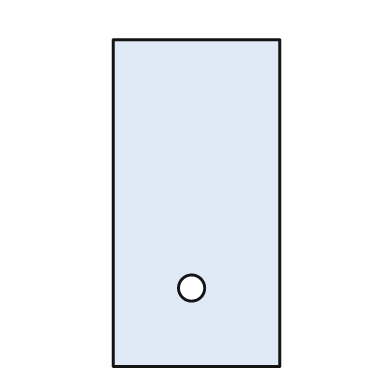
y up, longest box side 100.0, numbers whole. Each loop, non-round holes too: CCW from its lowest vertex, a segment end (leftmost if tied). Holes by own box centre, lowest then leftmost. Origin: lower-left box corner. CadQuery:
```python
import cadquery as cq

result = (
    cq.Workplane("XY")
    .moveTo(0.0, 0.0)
    .lineTo(51.0, 0.0)
    .lineTo(51.0, 100.0)
    .lineTo(0.0, 100.0)
    .close()
    .moveTo(24.0, 24.0)
    .circle(4.0)
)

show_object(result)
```